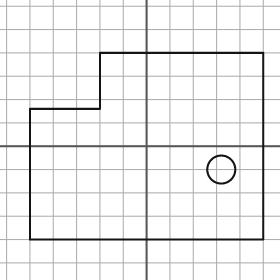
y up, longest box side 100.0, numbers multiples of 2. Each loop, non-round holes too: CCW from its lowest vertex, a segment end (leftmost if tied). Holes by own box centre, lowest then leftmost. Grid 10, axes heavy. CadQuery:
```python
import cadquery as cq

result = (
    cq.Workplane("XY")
    .moveTo(-50.0, -40.0)
    .lineTo(50.0, -40.0)
    .lineTo(50.0, 40.0)
    .lineTo(-20.0, 40.0)
    .lineTo(-20.0, 16.0)
    .lineTo(-50.0, 16.0)
    .close()
    .moveTo(32.0, -10.0)
    .circle(6.0)
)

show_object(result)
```